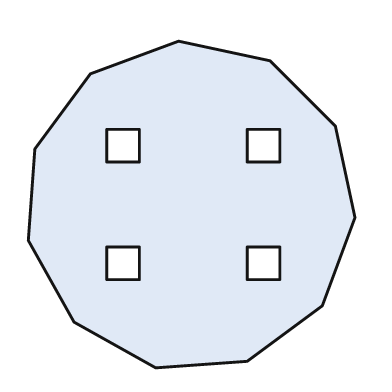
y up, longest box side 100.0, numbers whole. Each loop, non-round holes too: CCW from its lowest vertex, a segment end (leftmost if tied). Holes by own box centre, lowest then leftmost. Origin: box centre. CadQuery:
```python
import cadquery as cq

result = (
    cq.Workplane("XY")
    .moveTo(-11.0, -50.0)
    .lineTo(17.0, -48.0)
    .lineTo(40.0, -31.0)
    .lineTo(50.0, -4.0)
    .lineTo(44.0, 24.0)
    .lineTo(24.0, 44.0)
    .lineTo(-4.0, 50.0)
    .lineTo(-31.0, 40.0)
    .lineTo(-48.0, 17.0)
    .lineTo(-50.0, -11.0)
    .lineTo(-36.0, -36.0)
    .close()
    .moveTo(-26.0, -23.0)
    .lineTo(-16.0, -23.0)
    .lineTo(-16.0, -13.0)
    .lineTo(-26.0, -13.0)
    .close()
    .moveTo(17.0, -23.0)
    .lineTo(27.0, -23.0)
    .lineTo(27.0, -13.0)
    .lineTo(17.0, -13.0)
    .close()
    .moveTo(-26.0, 13.0)
    .lineTo(-16.0, 13.0)
    .lineTo(-16.0, 23.0)
    .lineTo(-26.0, 23.0)
    .close()
    .moveTo(17.0, 13.0)
    .lineTo(27.0, 13.0)
    .lineTo(27.0, 23.0)
    .lineTo(17.0, 23.0)
    .close()
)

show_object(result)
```